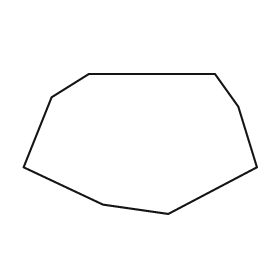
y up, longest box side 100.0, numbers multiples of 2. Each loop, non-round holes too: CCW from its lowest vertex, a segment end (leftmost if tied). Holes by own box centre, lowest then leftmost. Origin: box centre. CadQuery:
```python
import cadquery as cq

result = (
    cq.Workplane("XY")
    .moveTo(12.0, -30.0)
    .lineTo(50.0, -10.0)
    .lineTo(42.0, 16.0)
    .lineTo(32.0, 30.0)
    .lineTo(-22.0, 30.0)
    .lineTo(-38.0, 20.0)
    .lineTo(-50.0, -10.0)
    .lineTo(-16.0, -26.0)
    .close()
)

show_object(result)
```